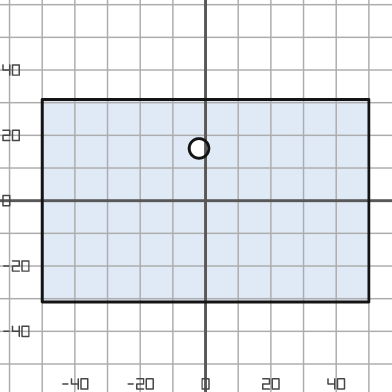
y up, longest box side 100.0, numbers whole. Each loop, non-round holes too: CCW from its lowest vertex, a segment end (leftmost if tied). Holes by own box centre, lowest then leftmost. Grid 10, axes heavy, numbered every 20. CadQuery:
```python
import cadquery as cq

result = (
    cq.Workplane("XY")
    .moveTo(-50.0, -31.0)
    .lineTo(50.0, -31.0)
    .lineTo(50.0, 31.0)
    .lineTo(-50.0, 31.0)
    .close()
    .moveTo(-2.0, 16.0)
    .circle(3.0)
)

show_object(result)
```